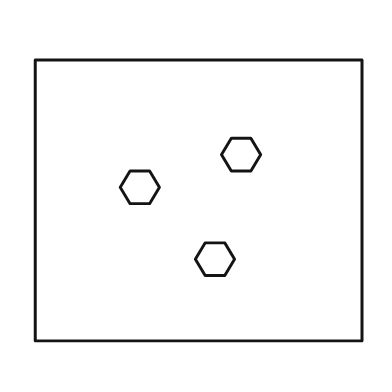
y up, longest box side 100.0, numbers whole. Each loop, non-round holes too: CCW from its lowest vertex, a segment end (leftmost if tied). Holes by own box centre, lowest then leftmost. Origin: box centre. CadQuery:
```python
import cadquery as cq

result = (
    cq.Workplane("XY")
    .moveTo(-50.0, -43.0)
    .lineTo(50.0, -43.0)
    .lineTo(50.0, 43.0)
    .lineTo(-50.0, 43.0)
    .close()
    .moveTo(2.0, -23.0)
    .lineTo(8.0, -23.0)
    .lineTo(11.0, -18.0)
    .lineTo(8.0, -13.0)
    .lineTo(2.0, -13.0)
    .lineTo(-1.0, -18.0)
    .close()
    .moveTo(-21.0, -1.0)
    .lineTo(-15.0, -1.0)
    .lineTo(-12.0, 4.0)
    .lineTo(-15.0, 9.0)
    .lineTo(-21.0, 9.0)
    .lineTo(-24.0, 4.0)
    .close()
    .moveTo(10.0, 9.0)
    .lineTo(16.0, 9.0)
    .lineTo(19.0, 14.0)
    .lineTo(16.0, 19.0)
    .lineTo(10.0, 19.0)
    .lineTo(7.0, 14.0)
    .close()
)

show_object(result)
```